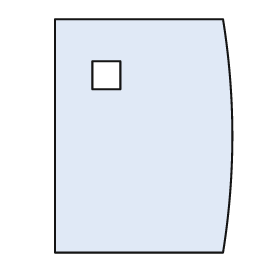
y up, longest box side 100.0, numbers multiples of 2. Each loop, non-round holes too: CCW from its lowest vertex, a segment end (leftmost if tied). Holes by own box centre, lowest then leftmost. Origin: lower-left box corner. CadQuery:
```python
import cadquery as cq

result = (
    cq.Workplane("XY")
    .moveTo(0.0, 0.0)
    .lineTo(72.0, 0.0)
    .threePointArc((76.0, 50.0), (72.0, 100.0))
    .lineTo(0.0, 100.0)
    .close()
    .moveTo(16.0, 70.0)
    .lineTo(28.0, 70.0)
    .lineTo(28.0, 82.0)
    .lineTo(16.0, 82.0)
    .close()
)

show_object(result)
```